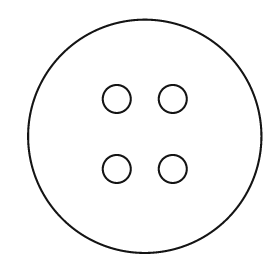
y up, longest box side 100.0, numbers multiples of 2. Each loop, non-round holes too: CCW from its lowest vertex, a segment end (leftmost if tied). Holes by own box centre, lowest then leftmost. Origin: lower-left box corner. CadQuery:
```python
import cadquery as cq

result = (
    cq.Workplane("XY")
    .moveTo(50.0, 50.0)
    .circle(50.0)
    .moveTo(38.0, 36.0)
    .circle(6.0)
    .moveTo(62.0, 36.0)
    .circle(6.0)
    .moveTo(38.0, 66.0)
    .circle(6.0)
    .moveTo(62.0, 66.0)
    .circle(6.0)
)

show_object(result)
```